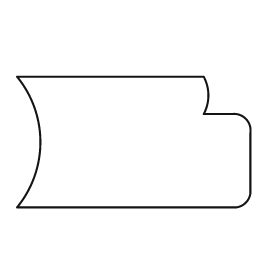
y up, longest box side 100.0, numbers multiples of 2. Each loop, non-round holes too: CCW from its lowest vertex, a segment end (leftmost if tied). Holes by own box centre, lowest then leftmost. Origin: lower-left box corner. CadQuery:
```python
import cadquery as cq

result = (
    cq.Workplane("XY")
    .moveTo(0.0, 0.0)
    .lineTo(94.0, 0.0)
    .threePointArc((98.0, 2.0), (100.0, 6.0))
    .lineTo(100.0, 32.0)
    .threePointArc((98.0, 38.0), (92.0, 40.0))
    .lineTo(80.0, 40.0)
    .threePointArc((82.0, 48.0), (80.0, 56.0))
    .lineTo(0.0, 56.0)
    .threePointArc((10.0, 28.0), (0.0, 0.0))
    .close()
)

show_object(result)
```